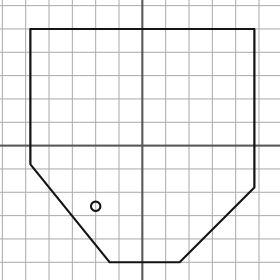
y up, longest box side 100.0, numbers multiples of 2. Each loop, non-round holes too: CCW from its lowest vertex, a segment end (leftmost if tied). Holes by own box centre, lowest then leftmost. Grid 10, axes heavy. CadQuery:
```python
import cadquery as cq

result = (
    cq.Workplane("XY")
    .moveTo(-14.0, -50.0)
    .lineTo(16.0, -50.0)
    .lineTo(48.0, -18.0)
    .lineTo(48.0, 50.0)
    .lineTo(-48.0, 50.0)
    .lineTo(-48.0, -8.0)
    .close()
    .moveTo(-20.0, -26.0)
    .circle(2.0)
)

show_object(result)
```